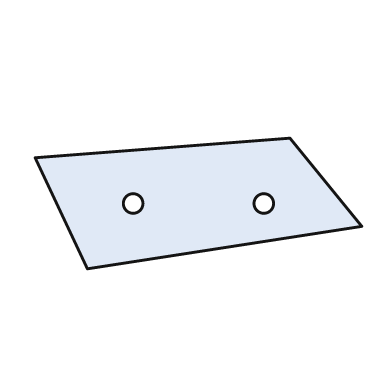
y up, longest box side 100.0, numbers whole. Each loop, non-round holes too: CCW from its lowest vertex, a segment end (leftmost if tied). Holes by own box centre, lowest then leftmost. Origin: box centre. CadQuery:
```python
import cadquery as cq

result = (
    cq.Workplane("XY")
    .moveTo(-34.0, -20.0)
    .lineTo(50.0, -7.0)
    .lineTo(28.0, 20.0)
    .lineTo(-50.0, 14.0)
    .close()
    .moveTo(-20.0, 0.0)
    .circle(3.0)
    .moveTo(20.0, 0.0)
    .circle(3.0)
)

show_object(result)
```